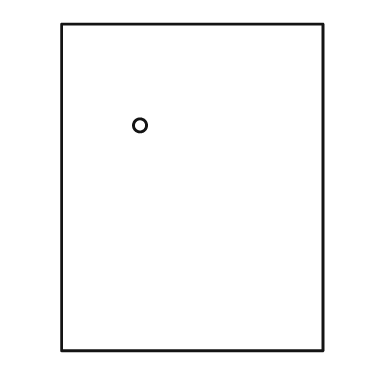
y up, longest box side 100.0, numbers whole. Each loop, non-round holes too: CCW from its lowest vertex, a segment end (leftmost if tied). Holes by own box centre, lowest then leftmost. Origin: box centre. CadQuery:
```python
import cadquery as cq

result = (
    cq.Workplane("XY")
    .moveTo(-40.0, -50.0)
    .lineTo(40.0, -50.0)
    .lineTo(40.0, 50.0)
    .lineTo(-40.0, 50.0)
    .close()
    .moveTo(-16.0, 19.0)
    .circle(2.0)
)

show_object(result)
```